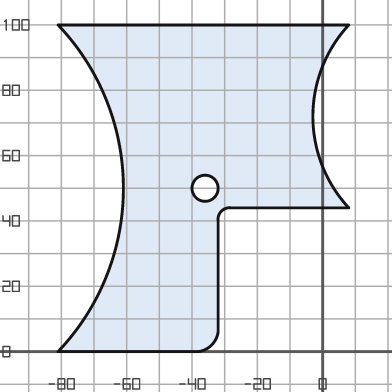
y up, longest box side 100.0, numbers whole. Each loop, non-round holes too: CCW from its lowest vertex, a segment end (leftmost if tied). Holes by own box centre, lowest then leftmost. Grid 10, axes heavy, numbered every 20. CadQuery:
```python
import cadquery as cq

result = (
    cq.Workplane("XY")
    .moveTo(-81.0, 0.0)
    .lineTo(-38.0, 0.0)
    .threePointArc((-34.0, 2.0), (-32.0, 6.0))
    .lineTo(-32.0, 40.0)
    .threePointArc((-31.0, 43.0), (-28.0, 44.0))
    .lineTo(8.0, 44.0)
    .threePointArc((-3.0, 72.0), (8.0, 100.0))
    .lineTo(-81.0, 100.0)
    .threePointArc((-61.0, 50.0), (-81.0, 0.0))
    .close()
    .moveTo(-36.0, 50.0)
    .circle(4.0)
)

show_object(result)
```